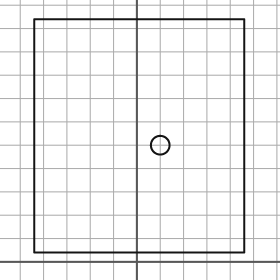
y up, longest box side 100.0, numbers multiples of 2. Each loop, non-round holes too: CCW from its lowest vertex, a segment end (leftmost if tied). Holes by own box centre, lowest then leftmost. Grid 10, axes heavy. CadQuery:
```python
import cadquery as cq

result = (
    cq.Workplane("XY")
    .moveTo(-44.0, 4.0)
    .lineTo(46.0, 4.0)
    .lineTo(46.0, 104.0)
    .lineTo(-44.0, 104.0)
    .close()
    .moveTo(10.0, 50.0)
    .circle(4.0)
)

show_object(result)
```